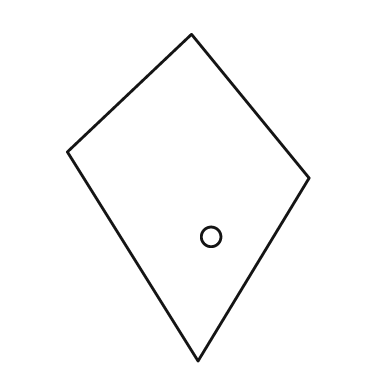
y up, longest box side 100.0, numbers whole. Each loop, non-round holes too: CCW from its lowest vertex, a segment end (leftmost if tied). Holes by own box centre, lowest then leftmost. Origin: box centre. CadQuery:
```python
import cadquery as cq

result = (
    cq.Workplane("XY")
    .moveTo(3.0, -50.0)
    .lineTo(37.0, 6.0)
    .lineTo(1.0, 50.0)
    .lineTo(-37.0, 14.0)
    .close()
    .moveTo(7.0, -12.0)
    .circle(3.0)
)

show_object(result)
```